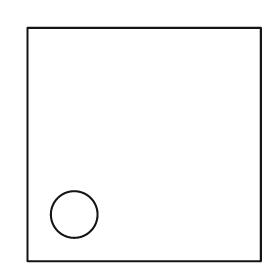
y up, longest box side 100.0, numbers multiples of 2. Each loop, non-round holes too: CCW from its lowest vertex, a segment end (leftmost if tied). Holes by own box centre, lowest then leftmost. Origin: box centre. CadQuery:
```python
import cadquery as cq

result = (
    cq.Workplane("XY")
    .moveTo(-50.0, -50.0)
    .lineTo(50.0, -50.0)
    .lineTo(50.0, 50.0)
    .lineTo(-50.0, 50.0)
    .close()
    .moveTo(-30.0, -30.0)
    .circle(10.0)
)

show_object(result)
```